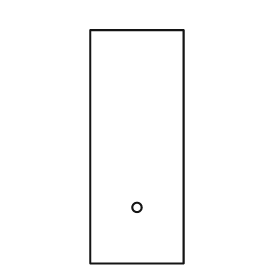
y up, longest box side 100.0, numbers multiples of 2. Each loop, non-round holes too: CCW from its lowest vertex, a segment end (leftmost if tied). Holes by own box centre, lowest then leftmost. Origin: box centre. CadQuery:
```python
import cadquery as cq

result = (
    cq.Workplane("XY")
    .moveTo(-20.0, -50.0)
    .lineTo(20.0, -50.0)
    .lineTo(20.0, 50.0)
    .lineTo(-20.0, 50.0)
    .close()
    .moveTo(0.0, -26.0)
    .circle(2.0)
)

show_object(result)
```